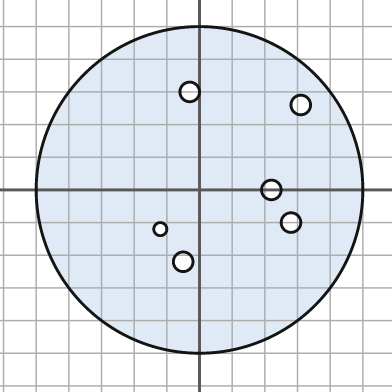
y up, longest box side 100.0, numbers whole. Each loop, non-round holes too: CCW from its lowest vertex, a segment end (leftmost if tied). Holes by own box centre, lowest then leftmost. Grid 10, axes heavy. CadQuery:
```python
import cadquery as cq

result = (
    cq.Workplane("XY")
    .moveTo(0.0, 0.0)
    .circle(50.0)
    .moveTo(-5.0, -22.0)
    .circle(3.0)
    .moveTo(-12.0, -12.0)
    .circle(2.0)
    .moveTo(28.0, -10.0)
    .circle(3.0)
    .moveTo(22.0, 0.0)
    .circle(3.0)
    .moveTo(31.0, 26.0)
    .circle(3.0)
    .moveTo(-3.0, 30.0)
    .circle(3.0)
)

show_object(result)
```